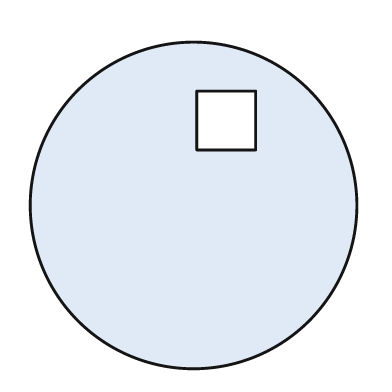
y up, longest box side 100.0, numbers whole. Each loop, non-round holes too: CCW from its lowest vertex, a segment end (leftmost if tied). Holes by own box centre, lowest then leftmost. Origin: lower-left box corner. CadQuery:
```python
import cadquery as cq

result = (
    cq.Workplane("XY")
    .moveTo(50.0, 50.0)
    .circle(50.0)
    .moveTo(51.0, 67.0)
    .lineTo(69.0, 67.0)
    .lineTo(69.0, 85.0)
    .lineTo(51.0, 85.0)
    .close()
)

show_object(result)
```